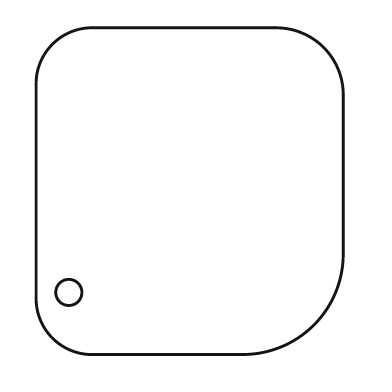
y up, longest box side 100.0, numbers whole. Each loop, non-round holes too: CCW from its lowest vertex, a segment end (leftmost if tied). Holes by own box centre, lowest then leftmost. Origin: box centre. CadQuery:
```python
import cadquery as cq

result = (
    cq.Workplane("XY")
    .moveTo(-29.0, -50.0)
    .lineTo(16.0, -50.0)
    .threePointArc((38.0, -41.0), (47.0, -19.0))
    .lineTo(47.0, 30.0)
    .threePointArc((41.0, 44.0), (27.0, 50.0))
    .lineTo(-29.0, 50.0)
    .threePointArc((-42.0, 45.0), (-47.0, 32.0))
    .lineTo(-47.0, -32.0)
    .threePointArc((-42.0, -45.0), (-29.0, -50.0))
    .close()
    .moveTo(-37.0, -31.0)
    .circle(4.0)
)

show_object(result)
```